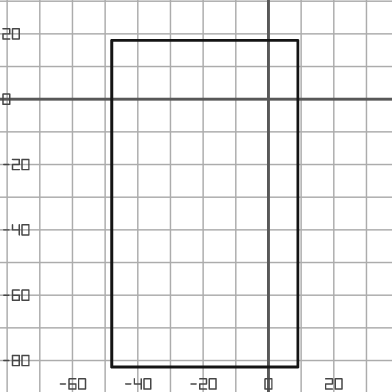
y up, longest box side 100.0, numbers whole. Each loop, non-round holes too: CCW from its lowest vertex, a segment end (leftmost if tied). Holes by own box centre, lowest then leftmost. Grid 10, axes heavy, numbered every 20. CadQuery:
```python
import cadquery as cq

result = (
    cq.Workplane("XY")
    .moveTo(-48.0, -82.0)
    .lineTo(9.0, -82.0)
    .lineTo(9.0, 18.0)
    .lineTo(-48.0, 18.0)
    .close()
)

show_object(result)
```